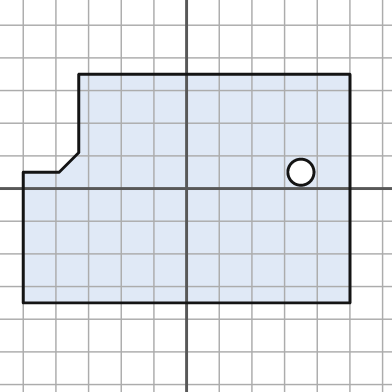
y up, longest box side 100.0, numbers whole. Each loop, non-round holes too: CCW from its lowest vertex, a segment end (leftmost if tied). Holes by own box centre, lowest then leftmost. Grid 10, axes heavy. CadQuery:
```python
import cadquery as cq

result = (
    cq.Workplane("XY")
    .moveTo(-50.0, -35.0)
    .lineTo(50.0, -35.0)
    .lineTo(50.0, 35.0)
    .lineTo(-33.0, 35.0)
    .lineTo(-33.0, 11.0)
    .lineTo(-39.0, 5.0)
    .lineTo(-50.0, 5.0)
    .close()
    .moveTo(35.0, 5.0)
    .circle(4.0)
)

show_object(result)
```